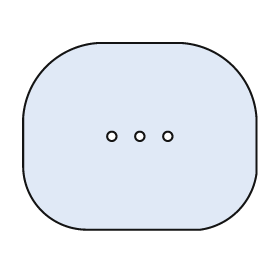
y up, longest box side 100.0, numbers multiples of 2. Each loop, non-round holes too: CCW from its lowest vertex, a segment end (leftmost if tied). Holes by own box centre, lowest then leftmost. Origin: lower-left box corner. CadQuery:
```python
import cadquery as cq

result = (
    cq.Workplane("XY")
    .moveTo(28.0, 0.0)
    .lineTo(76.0, 0.0)
    .threePointArc((92.0, 8.0), (100.0, 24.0))
    .lineTo(100.0, 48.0)
    .threePointArc((90.0, 70.0), (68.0, 80.0))
    .lineTo(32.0, 80.0)
    .threePointArc((10.0, 70.0), (0.0, 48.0))
    .lineTo(0.0, 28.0)
    .threePointArc((8.0, 8.0), (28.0, 0.0))
    .close()
    .moveTo(38.0, 40.0)
    .circle(2.0)
    .moveTo(50.0, 40.0)
    .circle(2.0)
    .moveTo(62.0, 40.0)
    .circle(2.0)
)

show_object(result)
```